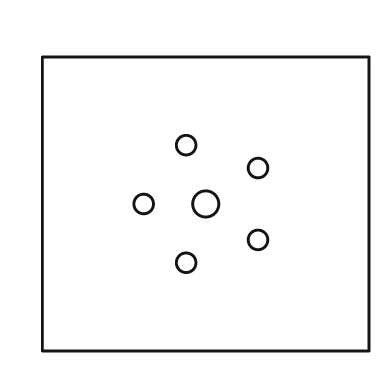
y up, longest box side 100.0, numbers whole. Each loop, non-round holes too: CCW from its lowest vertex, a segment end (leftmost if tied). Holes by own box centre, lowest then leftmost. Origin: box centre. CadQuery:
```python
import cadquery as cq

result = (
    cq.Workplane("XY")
    .moveTo(-50.0, -45.0)
    .lineTo(50.0, -45.0)
    .lineTo(50.0, 45.0)
    .lineTo(-50.0, 45.0)
    .close()
    .moveTo(-6.0, -18.0)
    .circle(3.0)
    .moveTo(16.0, -11.0)
    .circle(3.0)
    .moveTo(-19.0, 0.0)
    .circle(3.0)
    .moveTo(0.0, 0.0)
    .circle(4.0)
    .moveTo(16.0, 11.0)
    .circle(3.0)
    .moveTo(-6.0, 18.0)
    .circle(3.0)
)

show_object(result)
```